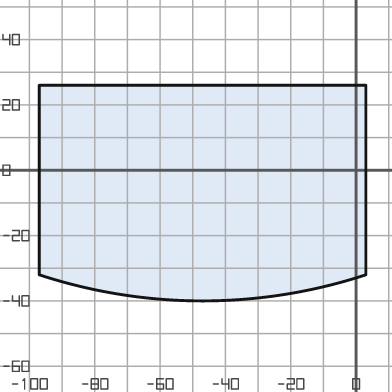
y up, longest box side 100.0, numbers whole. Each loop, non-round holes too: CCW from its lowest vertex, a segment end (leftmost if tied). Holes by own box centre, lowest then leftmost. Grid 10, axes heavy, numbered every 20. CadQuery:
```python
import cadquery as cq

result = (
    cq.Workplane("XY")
    .moveTo(-97.0, -32.0)
    .threePointArc((-47.0, -40.0), (3.0, -32.0))
    .lineTo(3.0, 26.0)
    .lineTo(-97.0, 26.0)
    .close()
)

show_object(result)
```